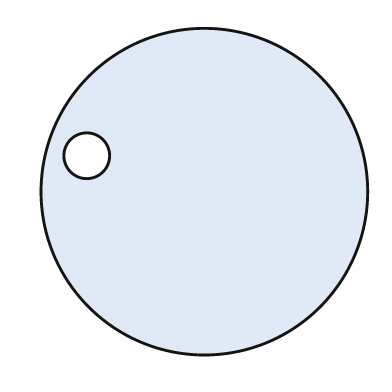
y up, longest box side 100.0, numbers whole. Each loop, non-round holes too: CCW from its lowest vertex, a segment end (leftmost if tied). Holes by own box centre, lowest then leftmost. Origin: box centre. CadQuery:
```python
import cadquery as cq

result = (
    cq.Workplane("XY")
    .moveTo(0.0, 0.0)
    .circle(50.0)
    .moveTo(-36.0, 11.0)
    .circle(7.0)
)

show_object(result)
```